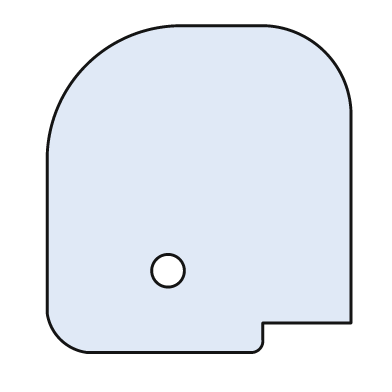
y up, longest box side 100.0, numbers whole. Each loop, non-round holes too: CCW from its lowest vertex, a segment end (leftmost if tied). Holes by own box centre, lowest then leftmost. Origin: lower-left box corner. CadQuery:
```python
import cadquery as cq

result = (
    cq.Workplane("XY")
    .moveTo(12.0, 0.0)
    .lineTo(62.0, 0.0)
    .threePointArc((65.0, 1.0), (66.0, 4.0))
    .lineTo(66.0, 9.0)
    .lineTo(93.0, 9.0)
    .lineTo(93.0, 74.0)
    .threePointArc((85.0, 92.0), (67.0, 100.0))
    .lineTo(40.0, 100.0)
    .threePointArc((12.0, 88.0), (0.0, 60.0))
    .lineTo(0.0, 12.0)
    .threePointArc((4.0, 4.0), (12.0, 0.0))
    .close()
    .moveTo(37.0, 25.0)
    .circle(5.0)
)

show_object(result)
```